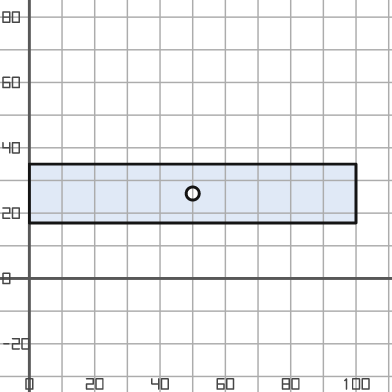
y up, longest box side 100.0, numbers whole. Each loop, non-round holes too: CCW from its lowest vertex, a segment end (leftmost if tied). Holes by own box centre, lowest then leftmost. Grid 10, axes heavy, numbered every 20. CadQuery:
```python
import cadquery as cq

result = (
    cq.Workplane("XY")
    .moveTo(0.0, 17.0)
    .lineTo(100.0, 17.0)
    .lineTo(100.0, 35.0)
    .lineTo(0.0, 35.0)
    .close()
    .moveTo(50.0, 26.0)
    .circle(2.0)
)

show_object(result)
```